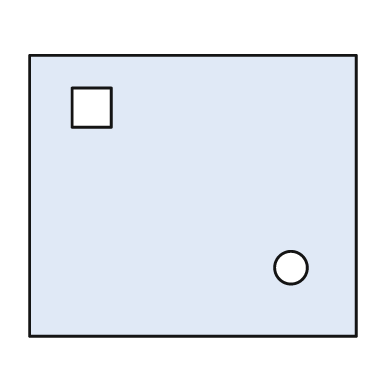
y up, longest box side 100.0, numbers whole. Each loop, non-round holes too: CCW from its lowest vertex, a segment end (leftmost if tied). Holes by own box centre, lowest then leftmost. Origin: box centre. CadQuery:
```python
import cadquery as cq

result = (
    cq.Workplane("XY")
    .moveTo(-50.0, -43.0)
    .lineTo(50.0, -43.0)
    .lineTo(50.0, 43.0)
    .lineTo(-50.0, 43.0)
    .close()
    .moveTo(30.0, -22.0)
    .circle(5.0)
    .moveTo(-37.0, 21.0)
    .lineTo(-25.0, 21.0)
    .lineTo(-25.0, 33.0)
    .lineTo(-37.0, 33.0)
    .close()
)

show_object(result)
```